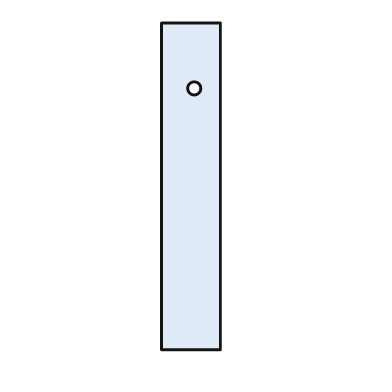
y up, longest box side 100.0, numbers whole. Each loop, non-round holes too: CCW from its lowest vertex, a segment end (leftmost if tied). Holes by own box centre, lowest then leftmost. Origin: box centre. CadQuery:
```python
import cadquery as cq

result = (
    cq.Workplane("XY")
    .moveTo(-9.0, -50.0)
    .lineTo(9.0, -50.0)
    .lineTo(9.0, 50.0)
    .lineTo(-9.0, 50.0)
    .close()
    .moveTo(1.0, 30.0)
    .circle(2.0)
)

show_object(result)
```